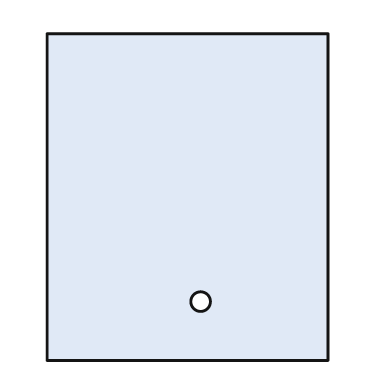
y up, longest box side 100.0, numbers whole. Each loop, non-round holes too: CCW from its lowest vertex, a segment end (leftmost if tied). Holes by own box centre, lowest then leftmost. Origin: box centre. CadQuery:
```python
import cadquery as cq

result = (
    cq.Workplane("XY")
    .moveTo(-43.0, -50.0)
    .lineTo(43.0, -50.0)
    .lineTo(43.0, 50.0)
    .lineTo(-43.0, 50.0)
    .close()
    .moveTo(4.0, -32.0)
    .circle(3.0)
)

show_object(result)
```